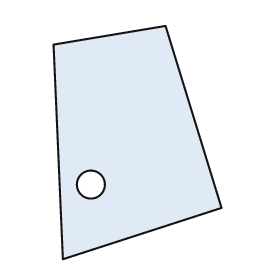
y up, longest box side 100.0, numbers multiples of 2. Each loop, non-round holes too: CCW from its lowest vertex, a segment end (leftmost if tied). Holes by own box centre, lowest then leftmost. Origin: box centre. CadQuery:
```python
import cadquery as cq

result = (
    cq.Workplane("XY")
    .moveTo(-32.0, -50.0)
    .lineTo(36.0, -28.0)
    .lineTo(12.0, 50.0)
    .lineTo(-36.0, 42.0)
    .close()
    .moveTo(-20.0, -18.0)
    .circle(6.0)
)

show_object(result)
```